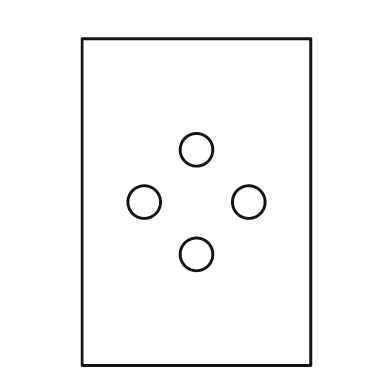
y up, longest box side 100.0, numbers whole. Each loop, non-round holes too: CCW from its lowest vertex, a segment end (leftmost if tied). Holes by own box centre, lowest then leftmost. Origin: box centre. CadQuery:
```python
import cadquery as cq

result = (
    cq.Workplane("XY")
    .moveTo(-35.0, -50.0)
    .lineTo(35.0, -50.0)
    .lineTo(35.0, 50.0)
    .lineTo(-35.0, 50.0)
    .close()
    .moveTo(0.0, -16.0)
    .circle(5.0)
    .moveTo(-16.0, 0.0)
    .circle(5.0)
    .moveTo(16.0, 0.0)
    .circle(5.0)
    .moveTo(0.0, 16.0)
    .circle(5.0)
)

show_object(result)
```